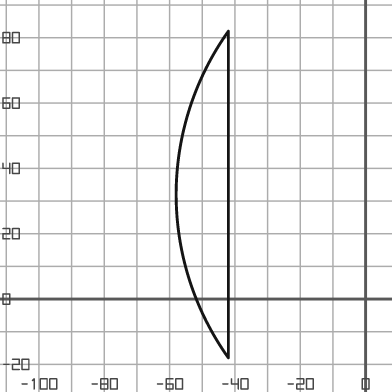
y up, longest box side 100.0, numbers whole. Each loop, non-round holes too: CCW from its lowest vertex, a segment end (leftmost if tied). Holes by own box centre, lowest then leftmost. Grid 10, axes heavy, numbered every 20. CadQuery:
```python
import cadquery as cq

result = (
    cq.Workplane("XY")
    .moveTo(-42.0, -18.0)
    .lineTo(-42.0, 82.0)
    .threePointArc((-58.0, 32.0), (-42.0, -18.0))
    .close()
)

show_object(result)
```